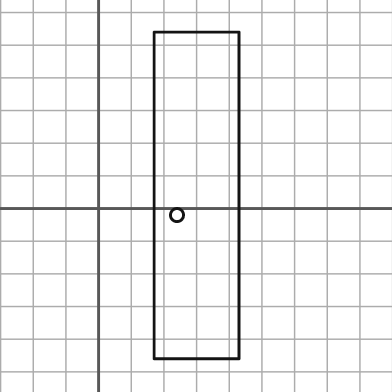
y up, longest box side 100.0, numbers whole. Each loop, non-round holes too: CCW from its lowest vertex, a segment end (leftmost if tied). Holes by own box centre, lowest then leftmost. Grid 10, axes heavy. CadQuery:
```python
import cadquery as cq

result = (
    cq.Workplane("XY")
    .moveTo(17.0, -46.0)
    .lineTo(43.0, -46.0)
    .lineTo(43.0, 54.0)
    .lineTo(17.0, 54.0)
    .close()
    .moveTo(24.0, -2.0)
    .circle(2.0)
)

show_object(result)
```